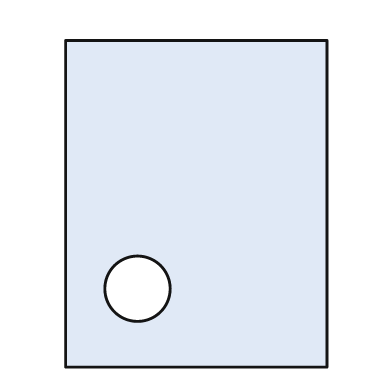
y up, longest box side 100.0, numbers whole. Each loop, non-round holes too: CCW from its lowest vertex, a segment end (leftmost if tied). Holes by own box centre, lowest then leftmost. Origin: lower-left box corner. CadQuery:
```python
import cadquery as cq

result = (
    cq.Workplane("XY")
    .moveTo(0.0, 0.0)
    .lineTo(80.0, 0.0)
    .lineTo(80.0, 100.0)
    .lineTo(0.0, 100.0)
    .close()
    .moveTo(22.0, 24.0)
    .circle(10.0)
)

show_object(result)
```